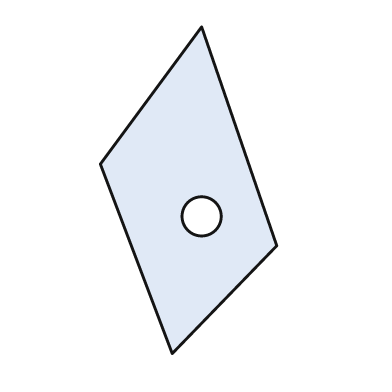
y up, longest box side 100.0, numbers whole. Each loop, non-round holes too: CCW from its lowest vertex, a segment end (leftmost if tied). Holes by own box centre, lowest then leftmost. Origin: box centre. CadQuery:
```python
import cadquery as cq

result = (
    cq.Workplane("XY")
    .moveTo(-5.0, -50.0)
    .lineTo(27.0, -17.0)
    .lineTo(4.0, 50.0)
    .lineTo(-27.0, 8.0)
    .close()
    .moveTo(4.0, -8.0)
    .circle(6.0)
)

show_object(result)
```